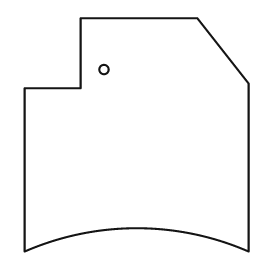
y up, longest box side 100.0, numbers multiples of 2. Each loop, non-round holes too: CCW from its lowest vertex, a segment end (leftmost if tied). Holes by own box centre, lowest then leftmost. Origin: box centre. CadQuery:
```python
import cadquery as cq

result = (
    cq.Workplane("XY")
    .moveTo(-48.0, -50.0)
    .threePointArc((0.0, -40.0), (48.0, -50.0))
    .lineTo(48.0, 22.0)
    .lineTo(26.0, 50.0)
    .lineTo(-24.0, 50.0)
    .lineTo(-24.0, 20.0)
    .lineTo(-48.0, 20.0)
    .close()
    .moveTo(-14.0, 28.0)
    .circle(2.0)
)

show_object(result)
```